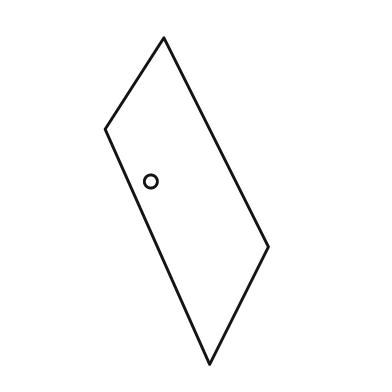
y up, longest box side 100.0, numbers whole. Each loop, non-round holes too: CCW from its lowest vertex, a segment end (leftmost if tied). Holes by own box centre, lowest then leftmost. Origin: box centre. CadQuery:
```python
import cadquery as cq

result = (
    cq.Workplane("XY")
    .moveTo(7.0, -50.0)
    .lineTo(25.0, -14.0)
    .lineTo(-7.0, 50.0)
    .lineTo(-25.0, 22.0)
    .close()
    .moveTo(-11.0, 6.0)
    .circle(2.0)
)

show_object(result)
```